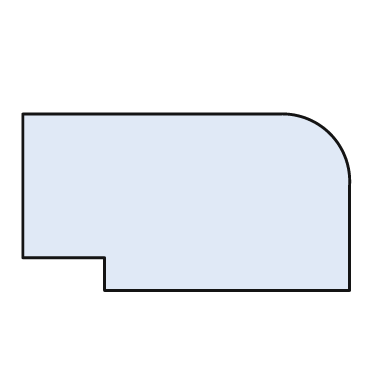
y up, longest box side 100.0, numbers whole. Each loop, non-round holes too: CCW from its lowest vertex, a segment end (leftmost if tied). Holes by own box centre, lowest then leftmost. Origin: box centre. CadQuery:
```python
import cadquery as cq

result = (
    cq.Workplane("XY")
    .moveTo(-25.0, -27.0)
    .lineTo(50.0, -27.0)
    .lineTo(50.0, 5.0)
    .threePointArc((44.0, 21.0), (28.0, 27.0))
    .lineTo(-50.0, 27.0)
    .lineTo(-50.0, -17.0)
    .lineTo(-25.0, -17.0)
    .close()
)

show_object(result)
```